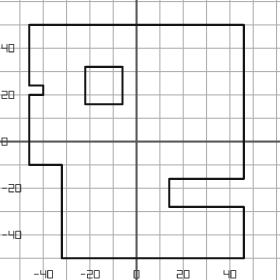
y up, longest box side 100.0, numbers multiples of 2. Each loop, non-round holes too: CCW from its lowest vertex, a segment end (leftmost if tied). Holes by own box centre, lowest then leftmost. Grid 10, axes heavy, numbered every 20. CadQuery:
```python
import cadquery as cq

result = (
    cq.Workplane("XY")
    .moveTo(-32.0, -50.0)
    .lineTo(46.0, -50.0)
    .lineTo(46.0, -28.0)
    .lineTo(14.0, -28.0)
    .lineTo(14.0, -16.0)
    .lineTo(46.0, -16.0)
    .lineTo(46.0, 50.0)
    .lineTo(-46.0, 50.0)
    .lineTo(-46.0, 24.0)
    .lineTo(-40.0, 24.0)
    .lineTo(-40.0, 20.0)
    .lineTo(-46.0, 20.0)
    .lineTo(-46.0, -10.0)
    .lineTo(-32.0, -10.0)
    .close()
    .moveTo(-22.0, 16.0)
    .lineTo(-6.0, 16.0)
    .lineTo(-6.0, 32.0)
    .lineTo(-22.0, 32.0)
    .close()
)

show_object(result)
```